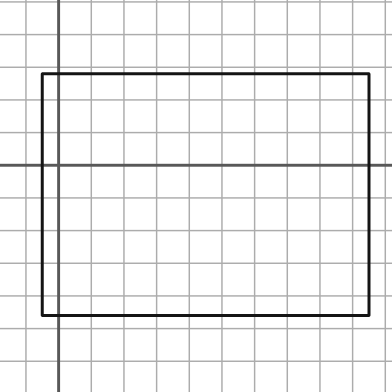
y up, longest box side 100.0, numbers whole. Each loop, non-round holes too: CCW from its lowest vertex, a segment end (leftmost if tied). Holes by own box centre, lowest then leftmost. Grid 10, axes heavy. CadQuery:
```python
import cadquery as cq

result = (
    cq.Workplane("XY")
    .moveTo(-5.0, -46.0)
    .lineTo(95.0, -46.0)
    .lineTo(95.0, 28.0)
    .lineTo(-5.0, 28.0)
    .close()
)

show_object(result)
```